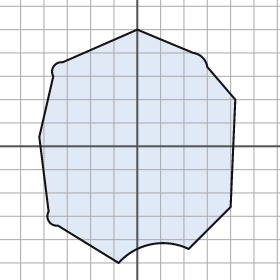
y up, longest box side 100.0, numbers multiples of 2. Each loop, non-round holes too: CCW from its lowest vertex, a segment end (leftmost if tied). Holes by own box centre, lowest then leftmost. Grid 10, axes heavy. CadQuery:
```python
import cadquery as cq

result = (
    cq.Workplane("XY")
    .moveTo(-8.0, -50.0)
    .threePointArc((6.0, -42.0), (22.0, -44.0))
    .lineTo(40.0, -26.0)
    .lineTo(42.0, 20.0)
    .lineTo(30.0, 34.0)
    .threePointArc((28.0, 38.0), (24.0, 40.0))
    .lineTo(0.0, 50.0)
    .lineTo(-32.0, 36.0)
    .threePointArc((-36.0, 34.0), (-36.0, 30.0))
    .lineTo(-42.0, 4.0)
    .lineTo(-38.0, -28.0)
    .threePointArc((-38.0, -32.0), (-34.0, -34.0))
    .close()
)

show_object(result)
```